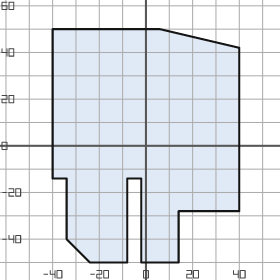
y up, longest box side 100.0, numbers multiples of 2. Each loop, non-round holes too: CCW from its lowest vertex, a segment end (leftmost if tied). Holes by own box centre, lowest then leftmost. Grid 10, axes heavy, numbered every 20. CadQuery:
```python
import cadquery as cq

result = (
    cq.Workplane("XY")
    .moveTo(-24.0, -50.0)
    .lineTo(-8.0, -50.0)
    .lineTo(-8.0, -14.0)
    .lineTo(-2.0, -14.0)
    .lineTo(-2.0, -50.0)
    .lineTo(14.0, -50.0)
    .lineTo(14.0, -28.0)
    .lineTo(40.0, -28.0)
    .lineTo(40.0, 42.0)
    .lineTo(6.0, 50.0)
    .lineTo(-40.0, 50.0)
    .lineTo(-40.0, -14.0)
    .lineTo(-34.0, -14.0)
    .lineTo(-34.0, -40.0)
    .close()
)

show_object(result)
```